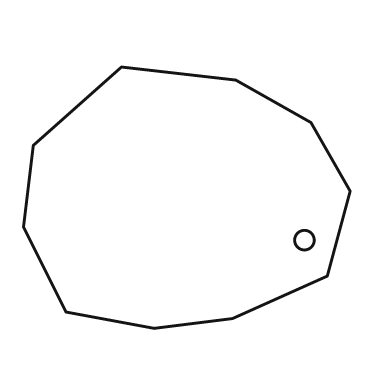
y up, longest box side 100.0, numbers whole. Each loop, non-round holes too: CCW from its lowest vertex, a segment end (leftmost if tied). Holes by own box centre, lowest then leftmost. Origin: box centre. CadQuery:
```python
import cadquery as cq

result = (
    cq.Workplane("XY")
    .moveTo(-10.0, -40.0)
    .lineTo(14.0, -37.0)
    .lineTo(43.0, -24.0)
    .lineTo(50.0, 2.0)
    .lineTo(38.0, 23.0)
    .lineTo(15.0, 36.0)
    .lineTo(-20.0, 40.0)
    .lineTo(-47.0, 16.0)
    .lineTo(-50.0, -9.0)
    .lineTo(-37.0, -35.0)
    .close()
    .moveTo(36.0, -13.0)
    .circle(3.0)
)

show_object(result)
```